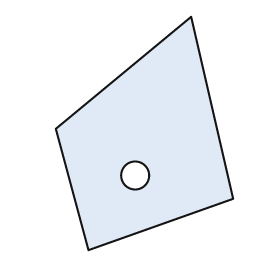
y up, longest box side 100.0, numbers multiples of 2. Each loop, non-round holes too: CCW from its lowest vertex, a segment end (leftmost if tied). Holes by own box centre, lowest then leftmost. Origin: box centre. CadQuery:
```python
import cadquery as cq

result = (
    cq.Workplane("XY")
    .moveTo(-24.0, -50.0)
    .lineTo(38.0, -28.0)
    .lineTo(20.0, 50.0)
    .lineTo(-38.0, 2.0)
    .close()
    .moveTo(-4.0, -18.0)
    .circle(6.0)
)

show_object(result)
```